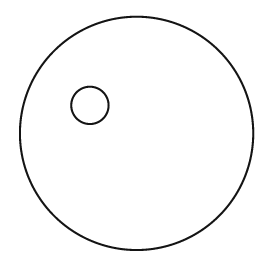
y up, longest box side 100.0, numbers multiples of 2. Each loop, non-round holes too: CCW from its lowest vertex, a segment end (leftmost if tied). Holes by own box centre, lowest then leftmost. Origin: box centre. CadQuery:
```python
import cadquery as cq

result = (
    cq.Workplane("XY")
    .moveTo(0.0, 0.0)
    .circle(50.0)
    .moveTo(-20.0, 12.0)
    .circle(8.0)
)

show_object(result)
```